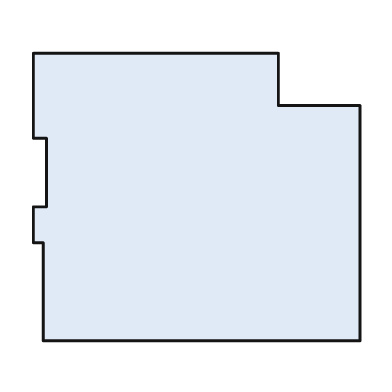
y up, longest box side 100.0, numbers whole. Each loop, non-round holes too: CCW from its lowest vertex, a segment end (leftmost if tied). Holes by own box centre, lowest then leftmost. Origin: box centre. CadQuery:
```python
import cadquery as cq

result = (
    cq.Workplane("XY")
    .moveTo(-47.0, -44.0)
    .lineTo(50.0, -44.0)
    .lineTo(50.0, 28.0)
    .lineTo(25.0, 28.0)
    .lineTo(25.0, 44.0)
    .lineTo(-50.0, 44.0)
    .lineTo(-50.0, 18.0)
    .lineTo(-46.0, 18.0)
    .lineTo(-46.0, -3.0)
    .lineTo(-50.0, -3.0)
    .lineTo(-50.0, -14.0)
    .lineTo(-47.0, -14.0)
    .close()
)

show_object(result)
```